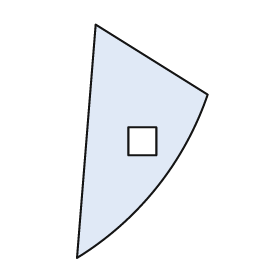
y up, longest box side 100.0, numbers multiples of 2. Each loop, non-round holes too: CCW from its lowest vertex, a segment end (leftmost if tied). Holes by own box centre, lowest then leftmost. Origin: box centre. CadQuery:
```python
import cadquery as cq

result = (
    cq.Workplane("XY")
    .moveTo(-28.0, -50.0)
    .threePointArc((6.0, -20.0), (28.0, 20.0))
    .lineTo(-20.0, 50.0)
    .close()
    .moveTo(-6.0, -6.0)
    .lineTo(6.0, -6.0)
    .lineTo(6.0, 6.0)
    .lineTo(-6.0, 6.0)
    .close()
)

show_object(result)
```